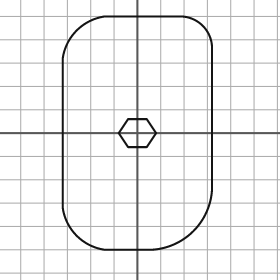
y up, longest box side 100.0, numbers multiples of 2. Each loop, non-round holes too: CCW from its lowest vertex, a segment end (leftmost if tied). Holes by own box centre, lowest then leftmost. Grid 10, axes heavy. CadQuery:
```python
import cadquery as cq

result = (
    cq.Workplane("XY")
    .moveTo(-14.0, -50.0)
    .lineTo(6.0, -50.0)
    .threePointArc((24.0, -42.0), (32.0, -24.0))
    .lineTo(32.0, 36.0)
    .threePointArc((28.0, 46.0), (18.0, 50.0))
    .lineTo(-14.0, 50.0)
    .threePointArc((-26.0, 44.0), (-32.0, 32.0))
    .lineTo(-32.0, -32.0)
    .threePointArc((-26.0, -44.0), (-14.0, -50.0))
    .close()
    .moveTo(-4.0, -6.0)
    .lineTo(4.0, -6.0)
    .lineTo(8.0, 0.0)
    .lineTo(4.0, 6.0)
    .lineTo(-4.0, 6.0)
    .lineTo(-8.0, 0.0)
    .close()
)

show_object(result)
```